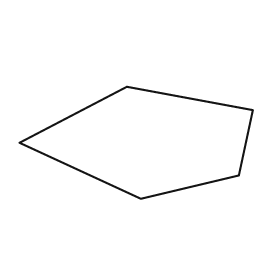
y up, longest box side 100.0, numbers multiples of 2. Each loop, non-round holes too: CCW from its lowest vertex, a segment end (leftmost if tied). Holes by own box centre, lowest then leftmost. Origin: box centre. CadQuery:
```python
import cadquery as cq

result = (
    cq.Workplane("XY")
    .moveTo(2.0, -24.0)
    .lineTo(44.0, -14.0)
    .lineTo(50.0, 14.0)
    .lineTo(-4.0, 24.0)
    .lineTo(-50.0, 0.0)
    .close()
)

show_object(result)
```